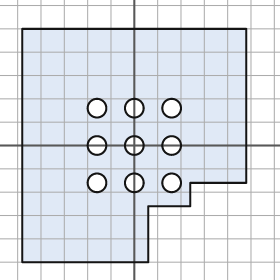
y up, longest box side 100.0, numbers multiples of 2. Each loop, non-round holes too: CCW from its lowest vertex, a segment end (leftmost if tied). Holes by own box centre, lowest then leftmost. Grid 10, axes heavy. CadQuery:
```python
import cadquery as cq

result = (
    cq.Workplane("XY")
    .moveTo(-48.0, -50.0)
    .lineTo(6.0, -50.0)
    .lineTo(6.0, -26.0)
    .lineTo(24.0, -26.0)
    .lineTo(24.0, -16.0)
    .lineTo(48.0, -16.0)
    .lineTo(48.0, 50.0)
    .lineTo(-48.0, 50.0)
    .close()
    .moveTo(-16.0, -16.0)
    .circle(4.0)
    .moveTo(0.0, -16.0)
    .circle(4.0)
    .moveTo(16.0, -16.0)
    .circle(4.0)
    .moveTo(-16.0, 0.0)
    .circle(4.0)
    .moveTo(0.0, 0.0)
    .circle(4.0)
    .moveTo(16.0, 0.0)
    .circle(4.0)
    .moveTo(-16.0, 16.0)
    .circle(4.0)
    .moveTo(0.0, 16.0)
    .circle(4.0)
    .moveTo(16.0, 16.0)
    .circle(4.0)
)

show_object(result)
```